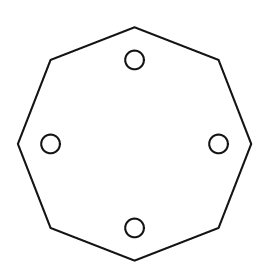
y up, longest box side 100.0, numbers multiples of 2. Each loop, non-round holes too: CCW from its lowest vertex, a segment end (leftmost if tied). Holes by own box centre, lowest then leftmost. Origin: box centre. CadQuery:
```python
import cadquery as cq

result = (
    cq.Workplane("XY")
    .moveTo(0.0, -50.0)
    .lineTo(36.0, -36.0)
    .lineTo(50.0, 0.0)
    .lineTo(36.0, 36.0)
    .lineTo(0.0, 50.0)
    .lineTo(-36.0, 36.0)
    .lineTo(-50.0, 0.0)
    .lineTo(-36.0, -36.0)
    .close()
    .moveTo(0.0, -36.0)
    .circle(4.0)
    .moveTo(-36.0, 0.0)
    .circle(4.0)
    .moveTo(36.0, 0.0)
    .circle(4.0)
    .moveTo(0.0, 36.0)
    .circle(4.0)
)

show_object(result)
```